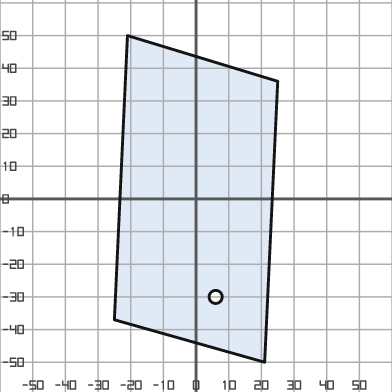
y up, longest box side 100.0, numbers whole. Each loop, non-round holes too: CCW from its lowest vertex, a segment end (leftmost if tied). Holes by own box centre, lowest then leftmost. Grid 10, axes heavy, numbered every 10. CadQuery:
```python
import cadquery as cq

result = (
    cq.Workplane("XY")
    .moveTo(21.0, -50.0)
    .lineTo(25.0, 36.0)
    .lineTo(-21.0, 50.0)
    .lineTo(-25.0, -37.0)
    .close()
    .moveTo(6.0, -30.0)
    .circle(2.0)
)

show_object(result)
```